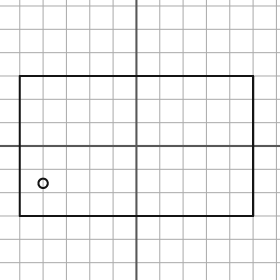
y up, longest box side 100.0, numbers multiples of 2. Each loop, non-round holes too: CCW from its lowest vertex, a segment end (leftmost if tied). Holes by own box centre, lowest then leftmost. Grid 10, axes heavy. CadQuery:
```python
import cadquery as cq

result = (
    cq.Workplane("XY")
    .moveTo(-50.0, -30.0)
    .lineTo(50.0, -30.0)
    .lineTo(50.0, 30.0)
    .lineTo(-50.0, 30.0)
    .close()
    .moveTo(-40.0, -16.0)
    .circle(2.0)
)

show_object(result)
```